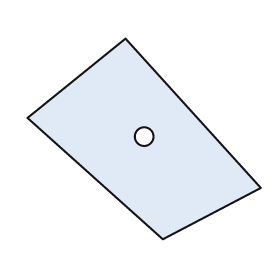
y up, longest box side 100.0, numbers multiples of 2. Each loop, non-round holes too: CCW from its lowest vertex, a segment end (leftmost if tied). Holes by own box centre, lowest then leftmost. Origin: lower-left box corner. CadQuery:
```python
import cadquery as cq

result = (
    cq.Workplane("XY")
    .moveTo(58.0, 0.0)
    .lineTo(100.0, 22.0)
    .lineTo(42.0, 86.0)
    .lineTo(0.0, 52.0)
    .close()
    .moveTo(50.0, 44.0)
    .circle(4.0)
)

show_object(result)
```